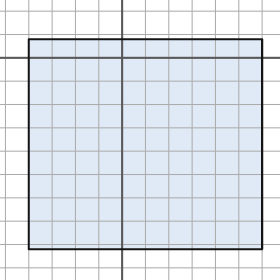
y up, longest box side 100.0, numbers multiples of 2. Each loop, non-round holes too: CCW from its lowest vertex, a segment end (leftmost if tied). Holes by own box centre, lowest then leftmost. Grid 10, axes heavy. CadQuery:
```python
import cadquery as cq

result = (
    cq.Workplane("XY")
    .moveTo(-40.0, -82.0)
    .lineTo(60.0, -82.0)
    .lineTo(60.0, 8.0)
    .lineTo(-40.0, 8.0)
    .close()
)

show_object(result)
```